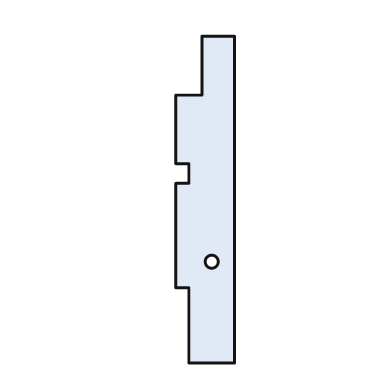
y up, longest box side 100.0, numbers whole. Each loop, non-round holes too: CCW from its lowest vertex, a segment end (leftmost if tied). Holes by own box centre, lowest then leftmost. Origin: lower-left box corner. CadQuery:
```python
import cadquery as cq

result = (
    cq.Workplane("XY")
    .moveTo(4.0, 0.0)
    .lineTo(18.0, 0.0)
    .lineTo(18.0, 100.0)
    .lineTo(8.0, 100.0)
    .lineTo(8.0, 82.0)
    .lineTo(0.0, 82.0)
    .lineTo(0.0, 61.0)
    .lineTo(4.0, 61.0)
    .lineTo(4.0, 55.0)
    .lineTo(0.0, 55.0)
    .lineTo(0.0, 23.0)
    .lineTo(4.0, 23.0)
    .close()
    .moveTo(11.0, 31.0)
    .circle(2.0)
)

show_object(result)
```